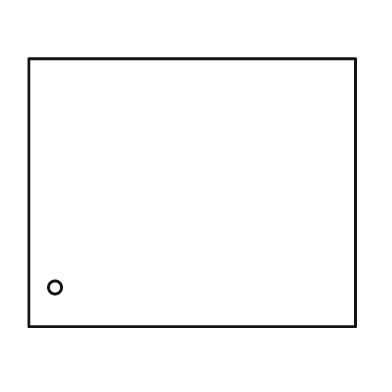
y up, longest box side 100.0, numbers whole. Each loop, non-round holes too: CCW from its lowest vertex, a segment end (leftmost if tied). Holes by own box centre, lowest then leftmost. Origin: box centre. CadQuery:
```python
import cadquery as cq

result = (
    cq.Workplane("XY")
    .moveTo(-50.0, -41.0)
    .lineTo(50.0, -41.0)
    .lineTo(50.0, 41.0)
    .lineTo(-50.0, 41.0)
    .close()
    .moveTo(-42.0, -29.0)
    .circle(2.0)
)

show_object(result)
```